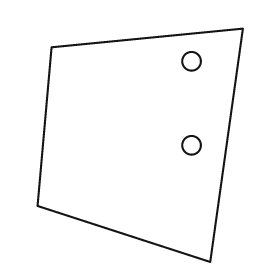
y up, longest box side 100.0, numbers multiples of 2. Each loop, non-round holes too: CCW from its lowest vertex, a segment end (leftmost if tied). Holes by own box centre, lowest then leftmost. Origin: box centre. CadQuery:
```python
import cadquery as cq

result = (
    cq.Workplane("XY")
    .moveTo(30.0, -50.0)
    .lineTo(44.0, 50.0)
    .lineTo(-38.0, 42.0)
    .lineTo(-44.0, -26.0)
    .close()
    .moveTo(22.0, 0.0)
    .circle(4.0)
    .moveTo(22.0, 36.0)
    .circle(4.0)
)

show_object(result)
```